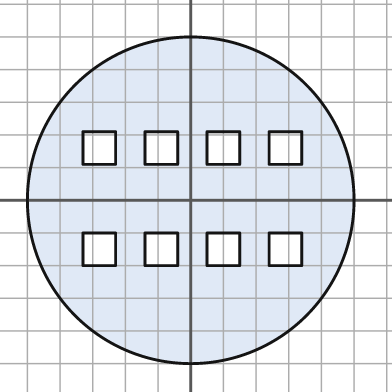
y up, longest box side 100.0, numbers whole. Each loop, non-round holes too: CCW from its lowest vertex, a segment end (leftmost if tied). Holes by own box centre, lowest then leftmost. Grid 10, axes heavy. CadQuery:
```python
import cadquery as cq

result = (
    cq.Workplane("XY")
    .moveTo(0.0, 0.0)
    .circle(50.0)
    .moveTo(-33.0, -20.0)
    .lineTo(-23.0, -20.0)
    .lineTo(-23.0, -10.0)
    .lineTo(-33.0, -10.0)
    .close()
    .moveTo(-14.0, -20.0)
    .lineTo(-4.0, -20.0)
    .lineTo(-4.0, -10.0)
    .lineTo(-14.0, -10.0)
    .close()
    .moveTo(5.0, -20.0)
    .lineTo(15.0, -20.0)
    .lineTo(15.0, -10.0)
    .lineTo(5.0, -10.0)
    .close()
    .moveTo(24.0, -20.0)
    .lineTo(34.0, -20.0)
    .lineTo(34.0, -10.0)
    .lineTo(24.0, -10.0)
    .close()
    .moveTo(-33.0, 11.0)
    .lineTo(-23.0, 11.0)
    .lineTo(-23.0, 21.0)
    .lineTo(-33.0, 21.0)
    .close()
    .moveTo(-14.0, 11.0)
    .lineTo(-4.0, 11.0)
    .lineTo(-4.0, 21.0)
    .lineTo(-14.0, 21.0)
    .close()
    .moveTo(5.0, 11.0)
    .lineTo(15.0, 11.0)
    .lineTo(15.0, 21.0)
    .lineTo(5.0, 21.0)
    .close()
    .moveTo(24.0, 11.0)
    .lineTo(34.0, 11.0)
    .lineTo(34.0, 21.0)
    .lineTo(24.0, 21.0)
    .close()
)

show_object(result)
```